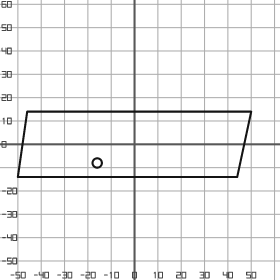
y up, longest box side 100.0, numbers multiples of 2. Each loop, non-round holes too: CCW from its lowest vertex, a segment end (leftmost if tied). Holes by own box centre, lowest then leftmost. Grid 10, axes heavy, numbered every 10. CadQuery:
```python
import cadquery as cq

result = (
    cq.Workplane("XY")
    .moveTo(-50.0, -14.0)
    .lineTo(44.0, -14.0)
    .lineTo(50.0, 14.0)
    .lineTo(-46.0, 14.0)
    .close()
    .moveTo(-16.0, -8.0)
    .circle(2.0)
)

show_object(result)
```